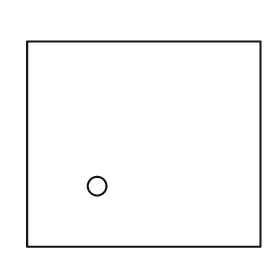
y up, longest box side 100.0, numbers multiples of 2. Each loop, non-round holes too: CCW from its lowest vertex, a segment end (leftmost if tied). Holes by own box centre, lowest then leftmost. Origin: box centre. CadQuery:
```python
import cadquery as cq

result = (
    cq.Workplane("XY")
    .moveTo(-50.0, -44.0)
    .lineTo(50.0, -44.0)
    .lineTo(50.0, 44.0)
    .lineTo(-50.0, 44.0)
    .close()
    .moveTo(-20.0, -18.0)
    .circle(4.0)
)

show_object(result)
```